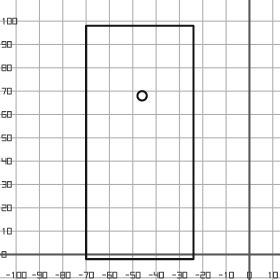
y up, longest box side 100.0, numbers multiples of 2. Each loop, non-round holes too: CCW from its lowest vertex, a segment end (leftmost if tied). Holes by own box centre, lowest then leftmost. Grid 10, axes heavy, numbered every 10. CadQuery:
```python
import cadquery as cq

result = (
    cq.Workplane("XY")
    .moveTo(-70.0, -2.0)
    .lineTo(-24.0, -2.0)
    .lineTo(-24.0, 98.0)
    .lineTo(-70.0, 98.0)
    .close()
    .moveTo(-46.0, 68.0)
    .circle(2.0)
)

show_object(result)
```